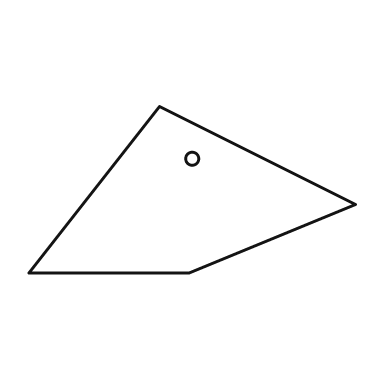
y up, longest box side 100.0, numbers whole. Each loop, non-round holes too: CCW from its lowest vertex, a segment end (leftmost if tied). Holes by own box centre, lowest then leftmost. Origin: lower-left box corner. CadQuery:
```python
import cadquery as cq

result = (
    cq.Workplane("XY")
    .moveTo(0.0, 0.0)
    .lineTo(49.0, 0.0)
    .lineTo(100.0, 21.0)
    .lineTo(40.0, 51.0)
    .close()
    .moveTo(50.0, 35.0)
    .circle(2.0)
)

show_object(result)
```